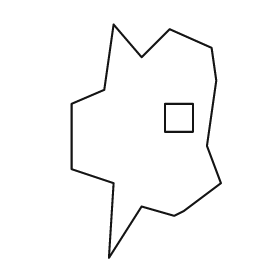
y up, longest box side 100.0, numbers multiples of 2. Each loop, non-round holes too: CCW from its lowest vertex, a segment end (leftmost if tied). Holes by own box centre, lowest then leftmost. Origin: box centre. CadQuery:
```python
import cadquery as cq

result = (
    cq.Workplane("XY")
    .moveTo(-16.0, -50.0)
    .lineTo(-2.0, -28.0)
    .lineTo(12.0, -32.0)
    .lineTo(16.0, -30.0)
    .lineTo(32.0, -18.0)
    .lineTo(26.0, -2.0)
    .lineTo(30.0, 26.0)
    .lineTo(28.0, 40.0)
    .lineTo(10.0, 48.0)
    .lineTo(-2.0, 36.0)
    .lineTo(-14.0, 50.0)
    .lineTo(-18.0, 22.0)
    .lineTo(-32.0, 16.0)
    .lineTo(-32.0, -12.0)
    .lineTo(-14.0, -18.0)
    .close()
    .moveTo(8.0, 4.0)
    .lineTo(20.0, 4.0)
    .lineTo(20.0, 16.0)
    .lineTo(8.0, 16.0)
    .close()
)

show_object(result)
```